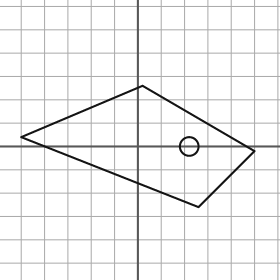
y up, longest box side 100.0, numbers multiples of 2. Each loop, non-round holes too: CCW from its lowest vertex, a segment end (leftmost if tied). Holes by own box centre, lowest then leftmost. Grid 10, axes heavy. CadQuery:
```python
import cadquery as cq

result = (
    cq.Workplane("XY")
    .moveTo(26.0, -26.0)
    .lineTo(50.0, -2.0)
    .lineTo(2.0, 26.0)
    .lineTo(-50.0, 4.0)
    .close()
    .moveTo(22.0, 0.0)
    .circle(4.0)
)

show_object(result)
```